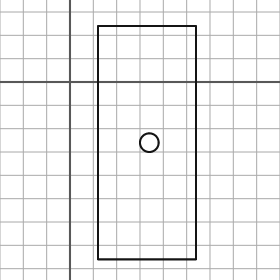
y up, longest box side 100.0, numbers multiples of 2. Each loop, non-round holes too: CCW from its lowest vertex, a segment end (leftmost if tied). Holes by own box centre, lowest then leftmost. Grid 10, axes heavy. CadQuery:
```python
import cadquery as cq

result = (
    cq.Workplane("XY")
    .moveTo(12.0, -76.0)
    .lineTo(54.0, -76.0)
    .lineTo(54.0, 24.0)
    .lineTo(12.0, 24.0)
    .close()
    .moveTo(34.0, -26.0)
    .circle(4.0)
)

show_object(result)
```